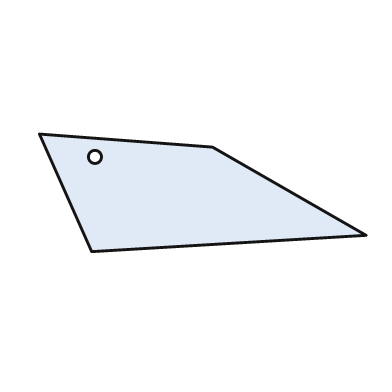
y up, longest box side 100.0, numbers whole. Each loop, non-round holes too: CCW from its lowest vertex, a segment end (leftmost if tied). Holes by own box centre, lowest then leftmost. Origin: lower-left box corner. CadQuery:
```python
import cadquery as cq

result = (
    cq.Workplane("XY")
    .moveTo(16.0, 0.0)
    .lineTo(100.0, 5.0)
    .lineTo(53.0, 32.0)
    .lineTo(0.0, 36.0)
    .close()
    .moveTo(17.0, 29.0)
    .circle(2.0)
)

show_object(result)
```